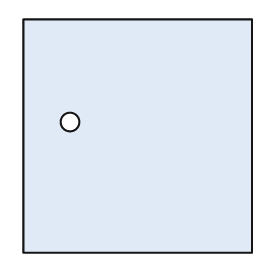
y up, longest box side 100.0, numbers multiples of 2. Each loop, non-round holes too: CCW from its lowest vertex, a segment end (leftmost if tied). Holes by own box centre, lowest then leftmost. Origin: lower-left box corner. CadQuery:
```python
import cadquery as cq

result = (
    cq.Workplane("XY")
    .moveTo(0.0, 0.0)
    .lineTo(98.0, 0.0)
    .lineTo(98.0, 100.0)
    .lineTo(0.0, 100.0)
    .close()
    .moveTo(20.0, 56.0)
    .circle(4.0)
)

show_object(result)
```